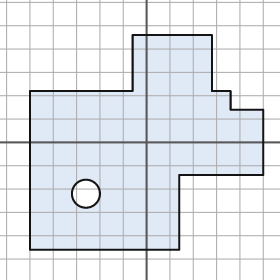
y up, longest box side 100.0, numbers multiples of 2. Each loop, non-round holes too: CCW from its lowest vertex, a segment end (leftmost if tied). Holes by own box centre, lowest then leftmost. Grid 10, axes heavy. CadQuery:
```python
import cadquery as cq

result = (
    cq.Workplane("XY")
    .moveTo(-50.0, -46.0)
    .lineTo(14.0, -46.0)
    .lineTo(14.0, -14.0)
    .lineTo(50.0, -14.0)
    .lineTo(50.0, 14.0)
    .lineTo(36.0, 14.0)
    .lineTo(36.0, 22.0)
    .lineTo(28.0, 22.0)
    .lineTo(28.0, 46.0)
    .lineTo(-6.0, 46.0)
    .lineTo(-6.0, 22.0)
    .lineTo(-50.0, 22.0)
    .close()
    .moveTo(-26.0, -22.0)
    .circle(6.0)
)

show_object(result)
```